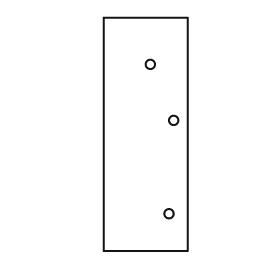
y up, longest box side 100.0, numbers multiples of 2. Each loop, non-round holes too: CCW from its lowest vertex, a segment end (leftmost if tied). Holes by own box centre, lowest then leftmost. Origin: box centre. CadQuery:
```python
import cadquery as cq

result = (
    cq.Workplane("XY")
    .moveTo(-18.0, -50.0)
    .lineTo(18.0, -50.0)
    .lineTo(18.0, 50.0)
    .lineTo(-18.0, 50.0)
    .close()
    .moveTo(10.0, -34.0)
    .circle(2.0)
    .moveTo(12.0, 6.0)
    .circle(2.0)
    .moveTo(2.0, 30.0)
    .circle(2.0)
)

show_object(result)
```